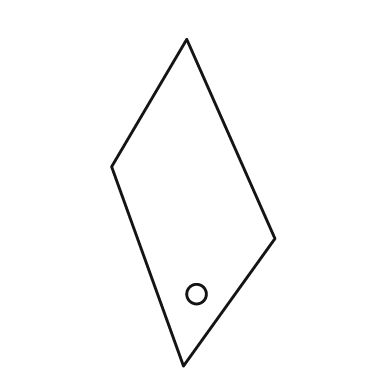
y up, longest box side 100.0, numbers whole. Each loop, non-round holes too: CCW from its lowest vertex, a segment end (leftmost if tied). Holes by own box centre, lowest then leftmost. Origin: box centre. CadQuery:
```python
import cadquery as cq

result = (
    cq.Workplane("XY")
    .moveTo(-3.0, -50.0)
    .lineTo(25.0, -11.0)
    .lineTo(-2.0, 50.0)
    .lineTo(-25.0, 11.0)
    .close()
    .moveTo(1.0, -28.0)
    .circle(3.0)
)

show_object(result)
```